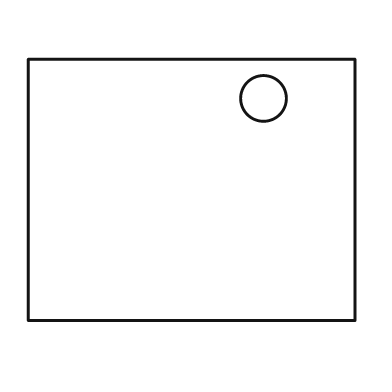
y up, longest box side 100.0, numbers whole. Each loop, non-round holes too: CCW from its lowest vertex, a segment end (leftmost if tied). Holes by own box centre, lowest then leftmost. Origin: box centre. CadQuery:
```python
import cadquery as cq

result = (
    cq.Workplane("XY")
    .moveTo(-50.0, -40.0)
    .lineTo(50.0, -40.0)
    .lineTo(50.0, 40.0)
    .lineTo(-50.0, 40.0)
    .close()
    .moveTo(22.0, 28.0)
    .circle(7.0)
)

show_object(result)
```